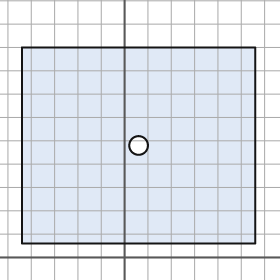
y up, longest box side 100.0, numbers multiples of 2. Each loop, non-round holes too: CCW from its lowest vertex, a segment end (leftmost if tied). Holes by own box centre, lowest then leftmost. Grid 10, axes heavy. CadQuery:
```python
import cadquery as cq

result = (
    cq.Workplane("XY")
    .moveTo(-44.0, 6.0)
    .lineTo(56.0, 6.0)
    .lineTo(56.0, 90.0)
    .lineTo(-44.0, 90.0)
    .close()
    .moveTo(6.0, 48.0)
    .circle(4.0)
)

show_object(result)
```